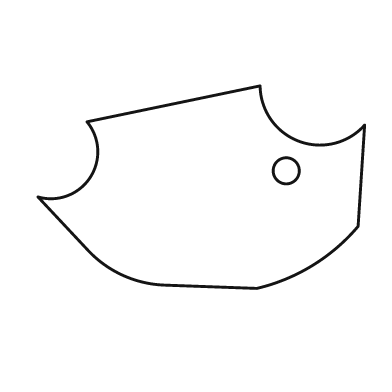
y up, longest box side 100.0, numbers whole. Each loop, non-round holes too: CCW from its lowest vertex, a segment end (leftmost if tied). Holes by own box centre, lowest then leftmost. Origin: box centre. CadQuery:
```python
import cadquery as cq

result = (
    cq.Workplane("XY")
    .moveTo(17.0, -31.0)
    .threePointArc((34.0, -24.0), (48.0, -12.0))
    .lineTo(50.0, 19.0)
    .threePointArc((30.0, 14.0), (18.0, 31.0))
    .lineTo(-35.0, 20.0)
    .threePointArc((-34.0, 3.0), (-50.0, -3.0))
    .lineTo(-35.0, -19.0)
    .threePointArc((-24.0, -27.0), (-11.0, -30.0))
    .close()
    .moveTo(26.0, 5.0)
    .circle(4.0)
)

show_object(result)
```